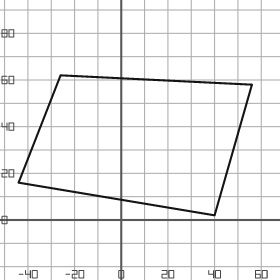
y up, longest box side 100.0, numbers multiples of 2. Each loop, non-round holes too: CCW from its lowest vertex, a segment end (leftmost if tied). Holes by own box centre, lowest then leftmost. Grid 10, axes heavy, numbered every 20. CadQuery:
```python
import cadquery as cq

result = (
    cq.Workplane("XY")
    .moveTo(40.0, 2.0)
    .lineTo(56.0, 58.0)
    .lineTo(-26.0, 62.0)
    .lineTo(-44.0, 16.0)
    .close()
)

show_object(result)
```